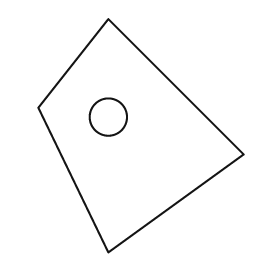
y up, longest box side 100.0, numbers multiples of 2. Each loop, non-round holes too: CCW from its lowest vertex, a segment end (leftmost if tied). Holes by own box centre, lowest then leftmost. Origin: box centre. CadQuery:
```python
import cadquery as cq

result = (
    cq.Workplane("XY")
    .moveTo(-14.0, -50.0)
    .lineTo(44.0, -8.0)
    .lineTo(-14.0, 50.0)
    .lineTo(-44.0, 12.0)
    .close()
    .moveTo(-14.0, 8.0)
    .circle(8.0)
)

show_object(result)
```